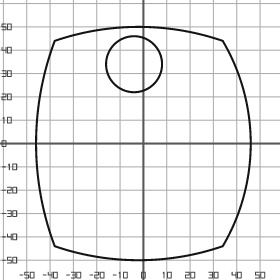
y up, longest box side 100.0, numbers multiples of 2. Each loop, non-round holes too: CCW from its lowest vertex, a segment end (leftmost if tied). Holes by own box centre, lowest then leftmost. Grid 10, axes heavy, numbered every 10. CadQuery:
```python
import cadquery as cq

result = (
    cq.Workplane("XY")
    .moveTo(-38.0, -44.0)
    .threePointArc((-2.0, -50.0), (34.0, -44.0))
    .threePointArc((46.0, 0.0), (34.0, 44.0))
    .threePointArc((-2.0, 50.0), (-38.0, 44.0))
    .threePointArc((-46.0, 0.0), (-38.0, -44.0))
    .close()
    .moveTo(-4.0, 34.0)
    .circle(12.0)
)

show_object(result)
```